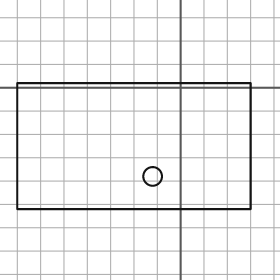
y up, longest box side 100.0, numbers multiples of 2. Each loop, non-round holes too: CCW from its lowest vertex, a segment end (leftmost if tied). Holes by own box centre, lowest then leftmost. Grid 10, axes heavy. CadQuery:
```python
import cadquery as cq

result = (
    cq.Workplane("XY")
    .moveTo(-70.0, -52.0)
    .lineTo(30.0, -52.0)
    .lineTo(30.0, 2.0)
    .lineTo(-70.0, 2.0)
    .close()
    .moveTo(-12.0, -38.0)
    .circle(4.0)
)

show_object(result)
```